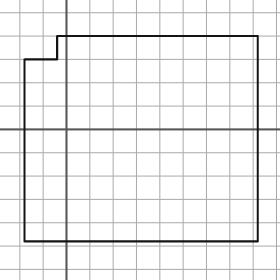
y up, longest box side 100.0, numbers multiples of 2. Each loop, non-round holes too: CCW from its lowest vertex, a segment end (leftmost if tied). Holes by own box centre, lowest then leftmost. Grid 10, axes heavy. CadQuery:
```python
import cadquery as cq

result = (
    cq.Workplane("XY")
    .moveTo(-18.0, -48.0)
    .lineTo(82.0, -48.0)
    .lineTo(82.0, 40.0)
    .lineTo(-4.0, 40.0)
    .lineTo(-4.0, 30.0)
    .lineTo(-18.0, 30.0)
    .close()
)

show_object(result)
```